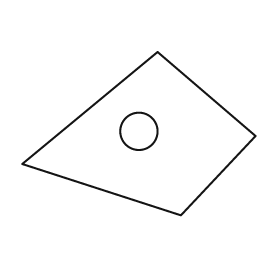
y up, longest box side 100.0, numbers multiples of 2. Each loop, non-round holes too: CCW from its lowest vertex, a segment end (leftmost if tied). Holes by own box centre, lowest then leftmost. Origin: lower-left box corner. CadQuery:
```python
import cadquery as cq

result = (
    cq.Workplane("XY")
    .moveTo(68.0, 0.0)
    .lineTo(100.0, 34.0)
    .lineTo(58.0, 70.0)
    .lineTo(0.0, 22.0)
    .close()
    .moveTo(50.0, 36.0)
    .circle(8.0)
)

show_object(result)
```